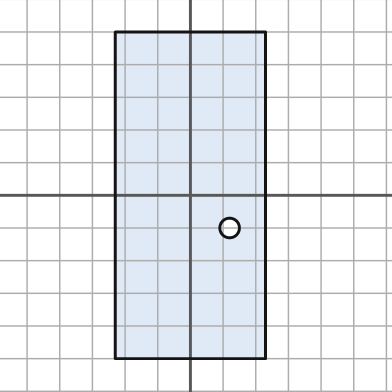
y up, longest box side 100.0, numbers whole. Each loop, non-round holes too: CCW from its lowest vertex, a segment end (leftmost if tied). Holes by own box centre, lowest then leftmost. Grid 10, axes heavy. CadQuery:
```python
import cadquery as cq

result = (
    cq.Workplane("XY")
    .moveTo(-23.0, -50.0)
    .lineTo(23.0, -50.0)
    .lineTo(23.0, 50.0)
    .lineTo(-23.0, 50.0)
    .close()
    .moveTo(12.0, -10.0)
    .circle(3.0)
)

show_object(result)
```